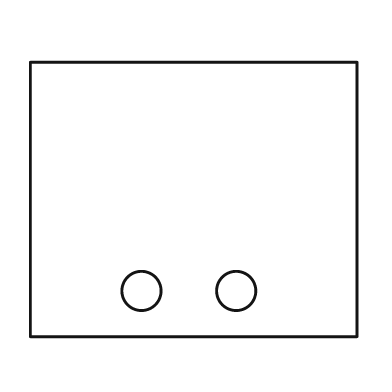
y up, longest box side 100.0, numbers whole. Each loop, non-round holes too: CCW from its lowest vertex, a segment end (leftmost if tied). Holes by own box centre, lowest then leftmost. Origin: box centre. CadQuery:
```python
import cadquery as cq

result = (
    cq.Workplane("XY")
    .moveTo(-50.0, -42.0)
    .lineTo(50.0, -42.0)
    .lineTo(50.0, 42.0)
    .lineTo(-50.0, 42.0)
    .close()
    .moveTo(-16.0, -28.0)
    .circle(6.0)
    .moveTo(13.0, -28.0)
    .circle(6.0)
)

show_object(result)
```